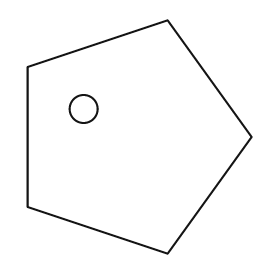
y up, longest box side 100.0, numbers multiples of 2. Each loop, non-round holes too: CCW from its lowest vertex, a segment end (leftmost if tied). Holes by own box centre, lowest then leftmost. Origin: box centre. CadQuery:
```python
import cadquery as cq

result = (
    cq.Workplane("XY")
    .moveTo(12.0, -50.0)
    .lineTo(48.0, 0.0)
    .lineTo(12.0, 50.0)
    .lineTo(-48.0, 30.0)
    .lineTo(-48.0, -30.0)
    .close()
    .moveTo(-24.0, 12.0)
    .circle(6.0)
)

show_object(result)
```